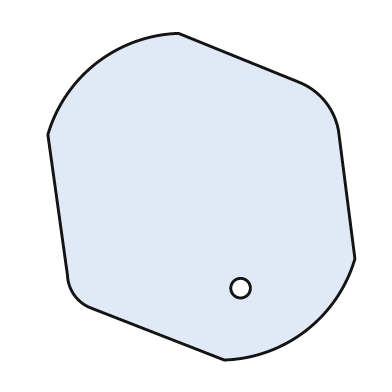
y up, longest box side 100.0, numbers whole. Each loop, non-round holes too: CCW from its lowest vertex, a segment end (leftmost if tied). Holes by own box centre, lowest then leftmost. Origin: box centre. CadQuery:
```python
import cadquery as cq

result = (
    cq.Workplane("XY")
    .moveTo(7.0, -50.0)
    .threePointArc((32.0, -41.0), (47.0, -19.0))
    .lineTo(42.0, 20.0)
    .threePointArc((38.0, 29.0), (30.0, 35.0))
    .lineTo(-7.0, 50.0)
    .threePointArc((-32.0, 41.0), (-47.0, 19.0))
    .lineTo(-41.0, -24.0)
    .threePointArc((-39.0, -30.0), (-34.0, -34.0))
    .close()
    .moveTo(12.0, -28.0)
    .circle(3.0)
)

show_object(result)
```